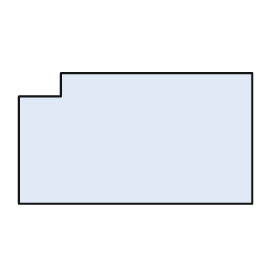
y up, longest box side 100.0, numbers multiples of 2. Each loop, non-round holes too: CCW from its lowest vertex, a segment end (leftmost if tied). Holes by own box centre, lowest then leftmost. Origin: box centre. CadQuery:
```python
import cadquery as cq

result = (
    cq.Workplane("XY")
    .moveTo(-50.0, -28.0)
    .lineTo(50.0, -28.0)
    .lineTo(50.0, 28.0)
    .lineTo(-32.0, 28.0)
    .lineTo(-32.0, 18.0)
    .lineTo(-50.0, 18.0)
    .close()
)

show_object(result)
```